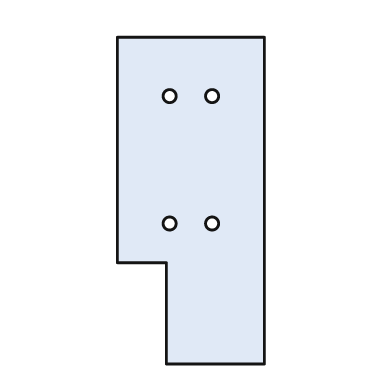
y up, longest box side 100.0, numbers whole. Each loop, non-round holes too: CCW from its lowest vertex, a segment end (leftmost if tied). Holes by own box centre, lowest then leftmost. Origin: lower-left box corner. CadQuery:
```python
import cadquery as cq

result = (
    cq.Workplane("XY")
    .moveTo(15.0, 0.0)
    .lineTo(45.0, 0.0)
    .lineTo(45.0, 100.0)
    .lineTo(0.0, 100.0)
    .lineTo(0.0, 31.0)
    .lineTo(15.0, 31.0)
    .close()
    .moveTo(16.0, 43.0)
    .circle(2.0)
    .moveTo(29.0, 43.0)
    .circle(2.0)
    .moveTo(16.0, 82.0)
    .circle(2.0)
    .moveTo(29.0, 82.0)
    .circle(2.0)
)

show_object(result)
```